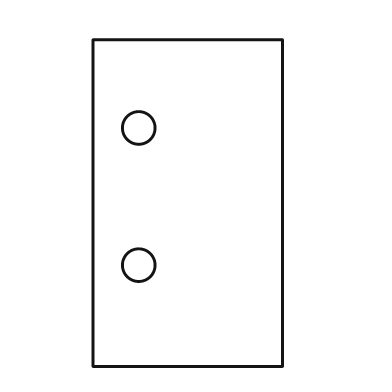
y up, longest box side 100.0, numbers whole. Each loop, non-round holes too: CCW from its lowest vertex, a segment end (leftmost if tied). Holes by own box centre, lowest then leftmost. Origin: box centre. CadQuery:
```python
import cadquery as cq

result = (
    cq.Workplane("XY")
    .moveTo(-29.0, -50.0)
    .lineTo(29.0, -50.0)
    .lineTo(29.0, 50.0)
    .lineTo(-29.0, 50.0)
    .close()
    .moveTo(-15.0, -19.0)
    .circle(5.0)
    .moveTo(-15.0, 23.0)
    .circle(5.0)
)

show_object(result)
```